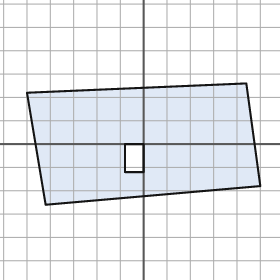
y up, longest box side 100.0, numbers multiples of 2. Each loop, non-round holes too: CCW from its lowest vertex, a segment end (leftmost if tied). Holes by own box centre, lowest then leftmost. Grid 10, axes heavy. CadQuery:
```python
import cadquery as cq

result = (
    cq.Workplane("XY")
    .moveTo(-42.0, -26.0)
    .lineTo(50.0, -18.0)
    .lineTo(44.0, 26.0)
    .lineTo(-50.0, 22.0)
    .close()
    .moveTo(-8.0, -12.0)
    .lineTo(0.0, -12.0)
    .lineTo(0.0, 0.0)
    .lineTo(-8.0, 0.0)
    .close()
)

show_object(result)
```